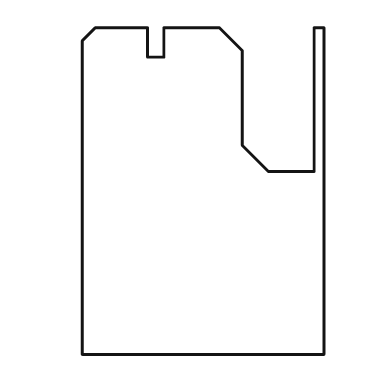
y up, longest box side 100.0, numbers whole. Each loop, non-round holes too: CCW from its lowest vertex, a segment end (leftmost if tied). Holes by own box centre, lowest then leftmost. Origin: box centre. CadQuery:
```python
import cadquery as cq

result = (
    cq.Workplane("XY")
    .moveTo(-37.0, -50.0)
    .lineTo(37.0, -50.0)
    .lineTo(37.0, 50.0)
    .lineTo(34.0, 50.0)
    .lineTo(34.0, 6.0)
    .lineTo(20.0, 6.0)
    .lineTo(12.0, 14.0)
    .lineTo(12.0, 43.0)
    .lineTo(5.0, 50.0)
    .lineTo(-12.0, 50.0)
    .lineTo(-12.0, 41.0)
    .lineTo(-17.0, 41.0)
    .lineTo(-17.0, 50.0)
    .lineTo(-33.0, 50.0)
    .lineTo(-37.0, 46.0)
    .close()
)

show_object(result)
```